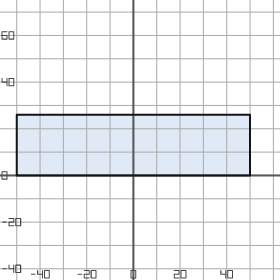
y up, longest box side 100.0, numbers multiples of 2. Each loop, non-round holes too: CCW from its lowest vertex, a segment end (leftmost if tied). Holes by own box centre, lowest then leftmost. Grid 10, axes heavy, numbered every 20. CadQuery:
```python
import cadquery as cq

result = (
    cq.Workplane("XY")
    .moveTo(-50.0, 0.0)
    .lineTo(50.0, 0.0)
    .lineTo(50.0, 26.0)
    .lineTo(-50.0, 26.0)
    .close()
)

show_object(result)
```